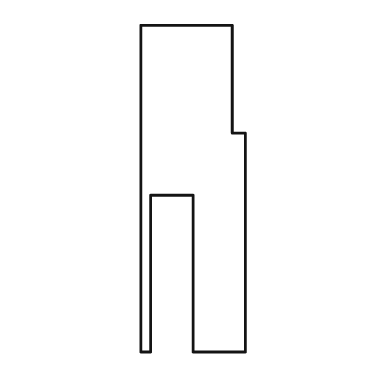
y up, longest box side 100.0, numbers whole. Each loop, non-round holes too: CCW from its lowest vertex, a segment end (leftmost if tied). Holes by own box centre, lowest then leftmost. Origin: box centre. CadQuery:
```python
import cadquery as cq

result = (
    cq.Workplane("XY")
    .moveTo(-16.0, -50.0)
    .lineTo(-13.0, -50.0)
    .lineTo(-13.0, -2.0)
    .lineTo(0.0, -2.0)
    .lineTo(0.0, -50.0)
    .lineTo(16.0, -50.0)
    .lineTo(16.0, 17.0)
    .lineTo(12.0, 17.0)
    .lineTo(12.0, 50.0)
    .lineTo(-16.0, 50.0)
    .close()
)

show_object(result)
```